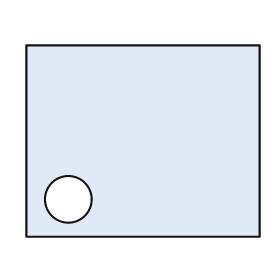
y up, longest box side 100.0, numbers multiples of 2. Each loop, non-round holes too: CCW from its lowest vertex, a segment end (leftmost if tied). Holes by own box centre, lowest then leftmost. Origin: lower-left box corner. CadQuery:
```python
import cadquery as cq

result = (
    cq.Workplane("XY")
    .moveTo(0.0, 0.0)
    .lineTo(100.0, 0.0)
    .lineTo(100.0, 82.0)
    .lineTo(0.0, 82.0)
    .close()
    .moveTo(18.0, 16.0)
    .circle(10.0)
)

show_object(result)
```